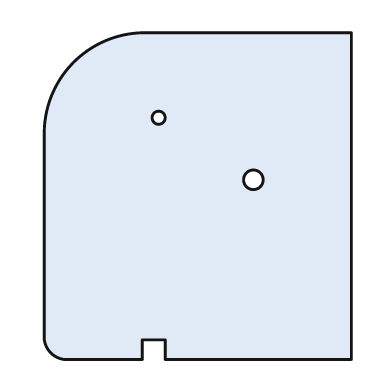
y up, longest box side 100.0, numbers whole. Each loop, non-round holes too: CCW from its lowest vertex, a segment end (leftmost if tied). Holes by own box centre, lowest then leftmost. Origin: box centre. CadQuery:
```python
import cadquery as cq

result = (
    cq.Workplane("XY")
    .moveTo(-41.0, -50.0)
    .lineTo(-17.0, -50.0)
    .lineTo(-17.0, -44.0)
    .lineTo(-10.0, -44.0)
    .lineTo(-10.0, -50.0)
    .lineTo(47.0, -50.0)
    .lineTo(47.0, 50.0)
    .lineTo(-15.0, 50.0)
    .threePointArc((-38.0, 41.0), (-47.0, 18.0))
    .lineTo(-47.0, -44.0)
    .threePointArc((-45.0, -48.0), (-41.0, -50.0))
    .close()
    .moveTo(17.0, 5.0)
    .circle(3.0)
    .moveTo(-12.0, 24.0)
    .circle(2.0)
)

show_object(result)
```